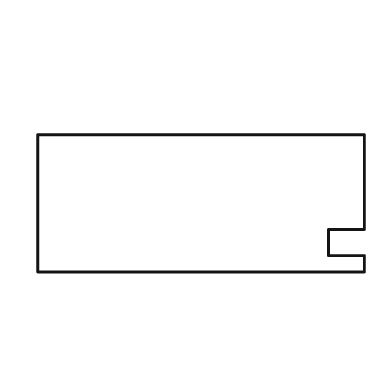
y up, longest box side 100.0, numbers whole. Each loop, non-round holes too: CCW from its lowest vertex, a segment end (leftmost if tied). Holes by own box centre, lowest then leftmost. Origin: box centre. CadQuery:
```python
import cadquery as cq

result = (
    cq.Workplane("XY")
    .moveTo(-50.0, -21.0)
    .lineTo(50.0, -21.0)
    .lineTo(50.0, -16.0)
    .lineTo(39.0, -16.0)
    .lineTo(39.0, -8.0)
    .lineTo(50.0, -8.0)
    .lineTo(50.0, 21.0)
    .lineTo(-50.0, 21.0)
    .close()
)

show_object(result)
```